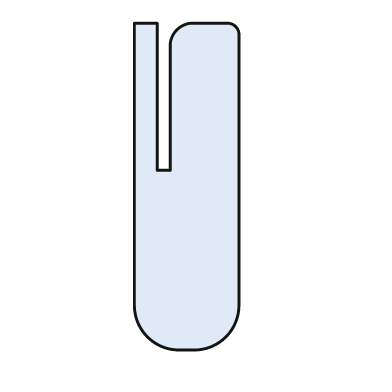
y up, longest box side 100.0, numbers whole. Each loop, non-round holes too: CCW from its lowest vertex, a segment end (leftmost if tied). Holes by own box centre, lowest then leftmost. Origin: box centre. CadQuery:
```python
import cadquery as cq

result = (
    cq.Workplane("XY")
    .moveTo(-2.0, -50.0)
    .lineTo(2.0, -50.0)
    .threePointArc((12.0, -46.0), (16.0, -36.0))
    .lineTo(16.0, 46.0)
    .threePointArc((15.0, 49.0), (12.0, 50.0))
    .lineTo(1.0, 50.0)
    .threePointArc((-3.0, 48.0), (-5.0, 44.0))
    .lineTo(-5.0, 5.0)
    .lineTo(-9.0, 5.0)
    .lineTo(-9.0, 50.0)
    .lineTo(-16.0, 50.0)
    .lineTo(-16.0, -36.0)
    .threePointArc((-12.0, -46.0), (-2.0, -50.0))
    .close()
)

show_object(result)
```